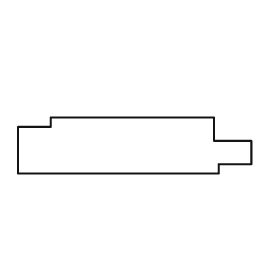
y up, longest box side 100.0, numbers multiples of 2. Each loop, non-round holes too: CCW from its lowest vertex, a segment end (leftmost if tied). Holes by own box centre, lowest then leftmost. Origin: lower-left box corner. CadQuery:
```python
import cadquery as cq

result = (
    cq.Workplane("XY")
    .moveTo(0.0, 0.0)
    .lineTo(86.0, 0.0)
    .lineTo(86.0, 4.0)
    .lineTo(100.0, 4.0)
    .lineTo(100.0, 14.0)
    .lineTo(84.0, 14.0)
    .lineTo(84.0, 24.0)
    .lineTo(14.0, 24.0)
    .lineTo(14.0, 20.0)
    .lineTo(0.0, 20.0)
    .close()
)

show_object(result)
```